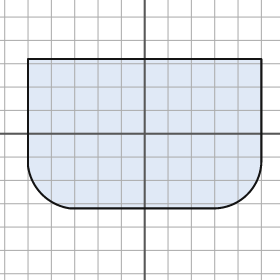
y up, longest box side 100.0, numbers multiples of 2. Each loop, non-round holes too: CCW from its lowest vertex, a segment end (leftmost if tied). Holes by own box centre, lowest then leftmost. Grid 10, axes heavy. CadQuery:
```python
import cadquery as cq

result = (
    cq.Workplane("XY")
    .moveTo(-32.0, -32.0)
    .lineTo(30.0, -32.0)
    .threePointArc((44.0, -26.0), (50.0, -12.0))
    .lineTo(50.0, 32.0)
    .lineTo(-50.0, 32.0)
    .lineTo(-50.0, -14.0)
    .threePointArc((-44.0, -26.0), (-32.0, -32.0))
    .close()
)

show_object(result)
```